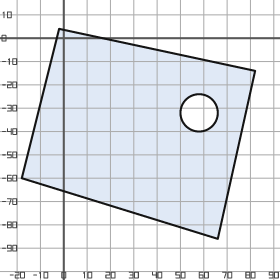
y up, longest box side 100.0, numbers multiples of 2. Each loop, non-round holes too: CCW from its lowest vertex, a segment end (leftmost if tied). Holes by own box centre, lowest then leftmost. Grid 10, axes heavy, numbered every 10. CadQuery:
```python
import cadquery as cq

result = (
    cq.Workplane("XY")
    .moveTo(66.0, -86.0)
    .lineTo(82.0, -14.0)
    .lineTo(-2.0, 4.0)
    .lineTo(-18.0, -60.0)
    .close()
    .moveTo(58.0, -32.0)
    .circle(8.0)
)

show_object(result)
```